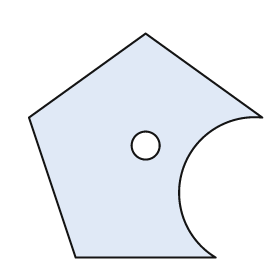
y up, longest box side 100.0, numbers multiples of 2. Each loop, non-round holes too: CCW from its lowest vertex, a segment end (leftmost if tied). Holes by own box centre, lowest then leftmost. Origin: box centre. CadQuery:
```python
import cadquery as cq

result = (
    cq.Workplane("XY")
    .moveTo(-30.0, -48.0)
    .lineTo(30.0, -48.0)
    .threePointArc((16.0, -10.0), (50.0, 12.0))
    .lineTo(0.0, 48.0)
    .lineTo(-50.0, 12.0)
    .close()
    .moveTo(0.0, 0.0)
    .circle(6.0)
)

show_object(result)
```